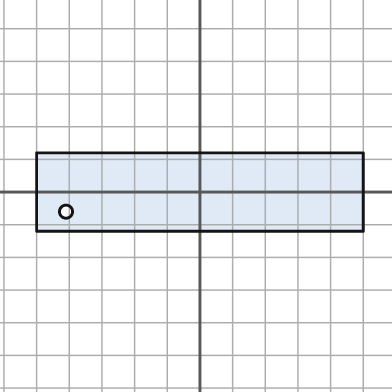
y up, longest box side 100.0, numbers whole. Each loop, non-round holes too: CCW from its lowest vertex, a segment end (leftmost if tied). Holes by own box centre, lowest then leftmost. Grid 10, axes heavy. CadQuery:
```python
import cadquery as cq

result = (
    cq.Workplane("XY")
    .moveTo(-50.0, -12.0)
    .lineTo(50.0, -12.0)
    .lineTo(50.0, 12.0)
    .lineTo(-50.0, 12.0)
    .close()
    .moveTo(-41.0, -6.0)
    .circle(2.0)
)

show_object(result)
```